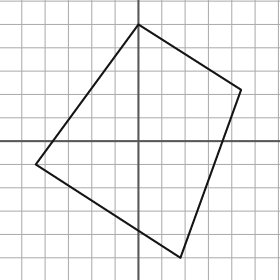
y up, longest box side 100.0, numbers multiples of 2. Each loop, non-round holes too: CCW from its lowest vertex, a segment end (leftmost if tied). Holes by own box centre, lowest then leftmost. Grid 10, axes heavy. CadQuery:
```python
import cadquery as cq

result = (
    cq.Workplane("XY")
    .moveTo(18.0, -50.0)
    .lineTo(44.0, 22.0)
    .lineTo(0.0, 50.0)
    .lineTo(-44.0, -10.0)
    .close()
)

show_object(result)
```